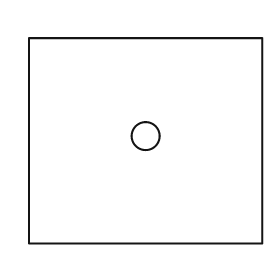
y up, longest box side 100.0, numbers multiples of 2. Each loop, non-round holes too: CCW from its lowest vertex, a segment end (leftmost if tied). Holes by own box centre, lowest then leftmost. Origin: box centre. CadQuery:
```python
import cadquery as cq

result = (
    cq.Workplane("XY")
    .moveTo(-50.0, -44.0)
    .lineTo(50.0, -44.0)
    .lineTo(50.0, 44.0)
    .lineTo(-50.0, 44.0)
    .close()
    .moveTo(0.0, 2.0)
    .circle(6.0)
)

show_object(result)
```